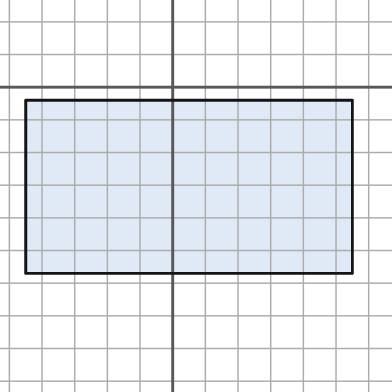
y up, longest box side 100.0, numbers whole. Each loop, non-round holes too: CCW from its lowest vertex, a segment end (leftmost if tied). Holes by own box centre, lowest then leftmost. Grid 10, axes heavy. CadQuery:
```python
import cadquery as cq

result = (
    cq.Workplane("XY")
    .moveTo(-45.0, -57.0)
    .lineTo(55.0, -57.0)
    .lineTo(55.0, -4.0)
    .lineTo(-45.0, -4.0)
    .close()
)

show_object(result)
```